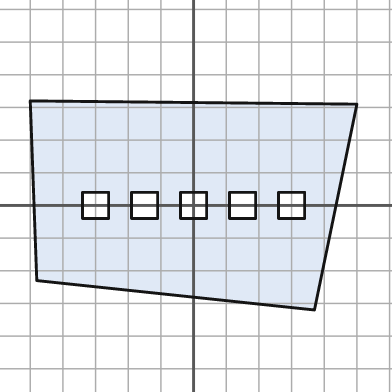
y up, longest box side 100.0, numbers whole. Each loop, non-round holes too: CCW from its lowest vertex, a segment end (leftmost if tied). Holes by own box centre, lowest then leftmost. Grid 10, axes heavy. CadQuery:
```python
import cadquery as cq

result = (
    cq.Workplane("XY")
    .moveTo(37.0, -32.0)
    .lineTo(50.0, 31.0)
    .lineTo(-50.0, 32.0)
    .lineTo(-48.0, -23.0)
    .close()
    .moveTo(-34.0, -4.0)
    .lineTo(-26.0, -4.0)
    .lineTo(-26.0, 4.0)
    .lineTo(-34.0, 4.0)
    .close()
    .moveTo(-19.0, -4.0)
    .lineTo(-11.0, -4.0)
    .lineTo(-11.0, 4.0)
    .lineTo(-19.0, 4.0)
    .close()
    .moveTo(-4.0, -4.0)
    .lineTo(4.0, -4.0)
    .lineTo(4.0, 4.0)
    .lineTo(-4.0, 4.0)
    .close()
    .moveTo(11.0, -4.0)
    .lineTo(19.0, -4.0)
    .lineTo(19.0, 4.0)
    .lineTo(11.0, 4.0)
    .close()
    .moveTo(26.0, -4.0)
    .lineTo(34.0, -4.0)
    .lineTo(34.0, 4.0)
    .lineTo(26.0, 4.0)
    .close()
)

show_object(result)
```